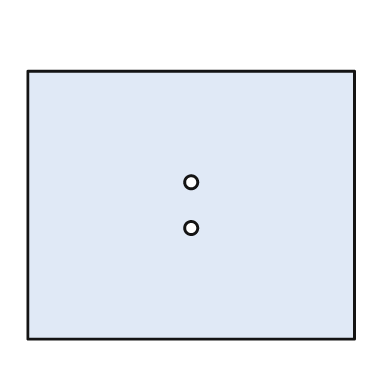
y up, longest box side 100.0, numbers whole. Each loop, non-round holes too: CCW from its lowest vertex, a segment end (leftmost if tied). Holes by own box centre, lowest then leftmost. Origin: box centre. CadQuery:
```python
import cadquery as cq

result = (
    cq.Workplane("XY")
    .moveTo(-50.0, -41.0)
    .lineTo(50.0, -41.0)
    .lineTo(50.0, 41.0)
    .lineTo(-50.0, 41.0)
    .close()
    .moveTo(0.0, -7.0)
    .circle(2.0)
    .moveTo(0.0, 7.0)
    .circle(2.0)
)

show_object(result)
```